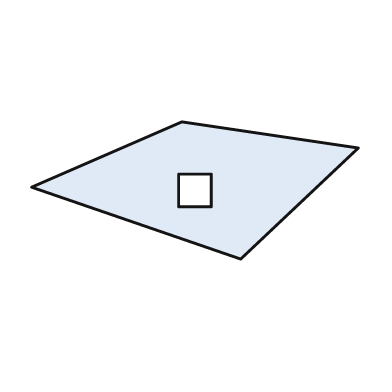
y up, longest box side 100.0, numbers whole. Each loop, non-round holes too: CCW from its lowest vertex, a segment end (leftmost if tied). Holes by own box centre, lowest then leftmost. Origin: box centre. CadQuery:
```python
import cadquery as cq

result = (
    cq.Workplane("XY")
    .moveTo(14.0, -21.0)
    .lineTo(50.0, 13.0)
    .lineTo(-4.0, 21.0)
    .lineTo(-50.0, 1.0)
    .close()
    .moveTo(-5.0, -5.0)
    .lineTo(5.0, -5.0)
    .lineTo(5.0, 5.0)
    .lineTo(-5.0, 5.0)
    .close()
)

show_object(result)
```